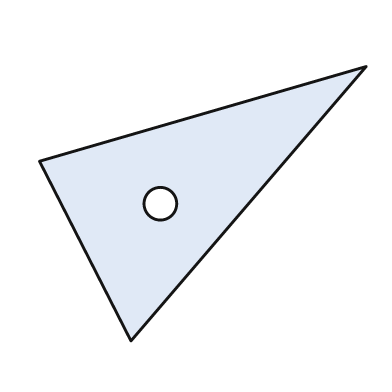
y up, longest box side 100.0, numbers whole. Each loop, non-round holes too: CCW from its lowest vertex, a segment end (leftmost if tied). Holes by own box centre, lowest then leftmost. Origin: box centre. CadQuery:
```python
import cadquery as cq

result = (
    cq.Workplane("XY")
    .moveTo(-22.0, -42.0)
    .lineTo(50.0, 42.0)
    .lineTo(-50.0, 13.0)
    .close()
    .moveTo(-13.0, 0.0)
    .circle(5.0)
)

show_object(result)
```